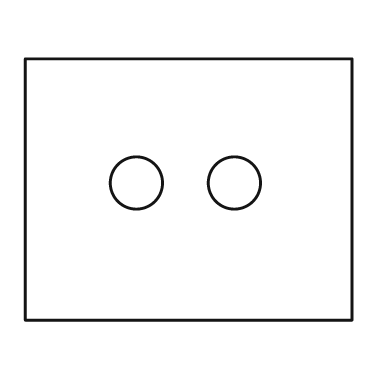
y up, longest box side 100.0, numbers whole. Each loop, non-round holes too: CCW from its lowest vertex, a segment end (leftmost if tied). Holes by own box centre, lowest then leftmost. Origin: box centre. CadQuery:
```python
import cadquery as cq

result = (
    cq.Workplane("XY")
    .moveTo(-50.0, -40.0)
    .lineTo(50.0, -40.0)
    .lineTo(50.0, 40.0)
    .lineTo(-50.0, 40.0)
    .close()
    .moveTo(-16.0, 2.0)
    .circle(8.0)
    .moveTo(14.0, 2.0)
    .circle(8.0)
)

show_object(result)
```